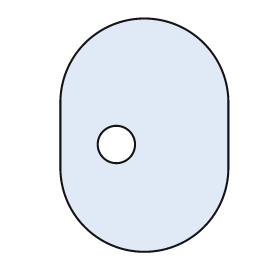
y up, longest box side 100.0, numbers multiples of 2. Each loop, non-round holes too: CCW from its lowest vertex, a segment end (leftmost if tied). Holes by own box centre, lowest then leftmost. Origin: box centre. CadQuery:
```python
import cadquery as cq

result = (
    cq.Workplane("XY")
    .moveTo(-36.0, -14.0)
    .threePointArc((0.0, -50.0), (36.0, -14.0))
    .lineTo(36.0, 14.0)
    .threePointArc((0.0, 50.0), (-36.0, 14.0))
    .close()
    .moveTo(-12.0, -4.0)
    .circle(8.0)
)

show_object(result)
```